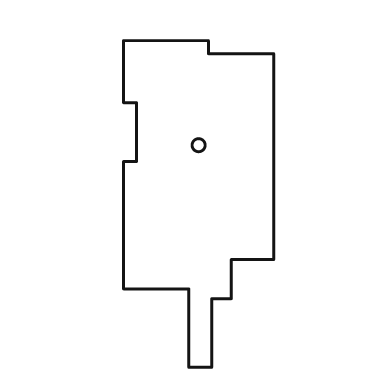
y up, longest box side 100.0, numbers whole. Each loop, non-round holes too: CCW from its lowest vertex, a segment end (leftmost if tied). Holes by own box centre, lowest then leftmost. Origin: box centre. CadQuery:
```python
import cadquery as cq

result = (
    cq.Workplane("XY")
    .moveTo(-3.0, -50.0)
    .lineTo(4.0, -50.0)
    .lineTo(4.0, -29.0)
    .lineTo(10.0, -29.0)
    .lineTo(10.0, -17.0)
    .lineTo(23.0, -17.0)
    .lineTo(23.0, 46.0)
    .lineTo(3.0, 46.0)
    .lineTo(3.0, 50.0)
    .lineTo(-23.0, 50.0)
    .lineTo(-23.0, 31.0)
    .lineTo(-19.0, 31.0)
    .lineTo(-19.0, 13.0)
    .lineTo(-23.0, 13.0)
    .lineTo(-23.0, -26.0)
    .lineTo(-3.0, -26.0)
    .close()
    .moveTo(0.0, 18.0)
    .circle(2.0)
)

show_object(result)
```